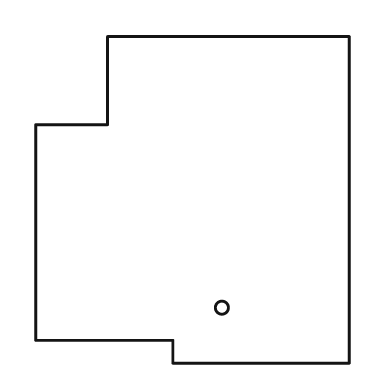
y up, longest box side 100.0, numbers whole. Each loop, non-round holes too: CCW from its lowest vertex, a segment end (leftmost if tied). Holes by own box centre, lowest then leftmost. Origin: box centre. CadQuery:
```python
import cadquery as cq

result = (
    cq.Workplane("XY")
    .moveTo(-6.0, -50.0)
    .lineTo(48.0, -50.0)
    .lineTo(48.0, 50.0)
    .lineTo(-26.0, 50.0)
    .lineTo(-26.0, 23.0)
    .lineTo(-48.0, 23.0)
    .lineTo(-48.0, -43.0)
    .lineTo(-6.0, -43.0)
    .close()
    .moveTo(9.0, -33.0)
    .circle(2.0)
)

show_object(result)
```